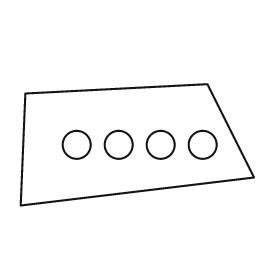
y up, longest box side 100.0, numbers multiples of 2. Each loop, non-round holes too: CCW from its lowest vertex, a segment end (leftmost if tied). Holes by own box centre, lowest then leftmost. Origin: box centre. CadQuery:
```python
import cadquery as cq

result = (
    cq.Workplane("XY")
    .moveTo(-50.0, -26.0)
    .lineTo(50.0, -14.0)
    .lineTo(30.0, 26.0)
    .lineTo(-48.0, 22.0)
    .close()
    .moveTo(-26.0, 0.0)
    .circle(6.0)
    .moveTo(-8.0, 0.0)
    .circle(6.0)
    .moveTo(10.0, 0.0)
    .circle(6.0)
    .moveTo(28.0, 0.0)
    .circle(6.0)
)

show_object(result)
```